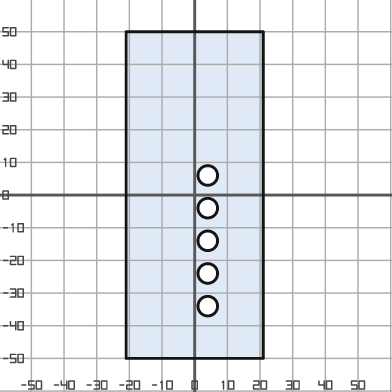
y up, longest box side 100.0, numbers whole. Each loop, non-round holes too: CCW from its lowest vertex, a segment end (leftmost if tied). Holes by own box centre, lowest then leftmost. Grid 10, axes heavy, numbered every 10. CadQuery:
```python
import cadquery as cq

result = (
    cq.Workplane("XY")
    .moveTo(-21.0, -50.0)
    .lineTo(21.0, -50.0)
    .lineTo(21.0, 50.0)
    .lineTo(-21.0, 50.0)
    .close()
    .moveTo(4.0, -34.0)
    .circle(3.0)
    .moveTo(4.0, -24.0)
    .circle(3.0)
    .moveTo(4.0, -14.0)
    .circle(3.0)
    .moveTo(4.0, -4.0)
    .circle(3.0)
    .moveTo(4.0, 6.0)
    .circle(3.0)
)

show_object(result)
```